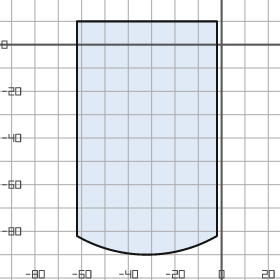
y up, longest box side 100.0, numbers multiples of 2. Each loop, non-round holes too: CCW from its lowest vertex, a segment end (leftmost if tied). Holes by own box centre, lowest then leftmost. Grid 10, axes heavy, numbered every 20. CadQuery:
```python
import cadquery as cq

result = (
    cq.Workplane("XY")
    .moveTo(-62.0, -82.0)
    .threePointArc((-32.0, -90.0), (-2.0, -82.0))
    .lineTo(-2.0, 10.0)
    .lineTo(-62.0, 10.0)
    .close()
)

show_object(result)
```